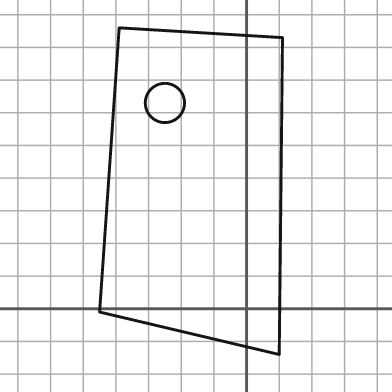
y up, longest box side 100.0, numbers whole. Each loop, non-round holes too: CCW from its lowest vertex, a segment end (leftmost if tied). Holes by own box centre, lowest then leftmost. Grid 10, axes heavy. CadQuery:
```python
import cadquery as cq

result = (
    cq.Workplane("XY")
    .moveTo(10.0, -14.0)
    .lineTo(11.0, 83.0)
    .lineTo(-39.0, 86.0)
    .lineTo(-45.0, -1.0)
    .close()
    .moveTo(-25.0, 63.0)
    .circle(6.0)
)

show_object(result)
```